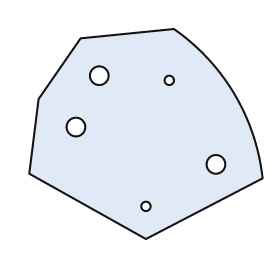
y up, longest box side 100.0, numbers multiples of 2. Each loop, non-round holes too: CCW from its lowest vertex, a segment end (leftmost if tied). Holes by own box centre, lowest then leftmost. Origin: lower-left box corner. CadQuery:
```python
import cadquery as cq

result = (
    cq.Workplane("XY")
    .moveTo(50.0, 0.0)
    .lineTo(100.0, 26.0)
    .threePointArc((88.0, 62.0), (62.0, 90.0))
    .lineTo(22.0, 86.0)
    .lineTo(4.0, 60.0)
    .lineTo(0.0, 28.0)
    .close()
    .moveTo(50.0, 14.0)
    .circle(2.0)
    .moveTo(80.0, 32.0)
    .circle(4.0)
    .moveTo(20.0, 48.0)
    .circle(4.0)
    .moveTo(60.0, 68.0)
    .circle(2.0)
    .moveTo(30.0, 70.0)
    .circle(4.0)
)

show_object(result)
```